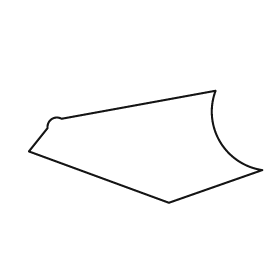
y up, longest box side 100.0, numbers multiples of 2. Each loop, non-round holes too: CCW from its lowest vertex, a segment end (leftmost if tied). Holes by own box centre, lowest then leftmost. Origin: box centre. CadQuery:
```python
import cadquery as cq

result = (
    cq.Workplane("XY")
    .moveTo(10.0, -24.0)
    .lineTo(50.0, -10.0)
    .threePointArc((32.0, 2.0), (30.0, 24.0))
    .lineTo(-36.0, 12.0)
    .threePointArc((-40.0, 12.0), (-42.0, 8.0))
    .lineTo(-50.0, -2.0)
    .close()
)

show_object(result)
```